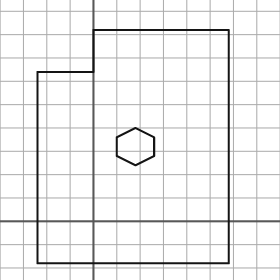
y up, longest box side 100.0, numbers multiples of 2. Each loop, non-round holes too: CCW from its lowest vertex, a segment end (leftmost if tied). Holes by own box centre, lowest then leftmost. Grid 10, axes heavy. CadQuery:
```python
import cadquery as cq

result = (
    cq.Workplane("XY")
    .moveTo(-24.0, -18.0)
    .lineTo(58.0, -18.0)
    .lineTo(58.0, 82.0)
    .lineTo(0.0, 82.0)
    .lineTo(0.0, 64.0)
    .lineTo(-24.0, 64.0)
    .close()
    .moveTo(18.0, 24.0)
    .lineTo(26.0, 28.0)
    .lineTo(26.0, 36.0)
    .lineTo(18.0, 40.0)
    .lineTo(10.0, 36.0)
    .lineTo(10.0, 28.0)
    .close()
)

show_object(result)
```